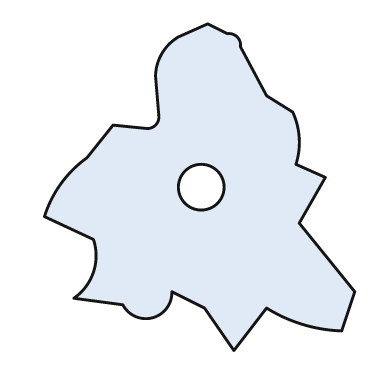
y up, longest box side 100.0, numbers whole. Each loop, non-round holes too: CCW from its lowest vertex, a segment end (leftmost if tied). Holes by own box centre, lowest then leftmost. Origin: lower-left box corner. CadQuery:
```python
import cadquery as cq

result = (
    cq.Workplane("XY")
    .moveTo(58.0, 0.0)
    .lineTo(68.0, 13.0)
    .threePointArc((79.0, 8.0), (91.0, 6.0))
    .lineTo(95.0, 18.0)
    .lineTo(78.0, 39.0)
    .lineTo(86.0, 53.0)
    .lineTo(77.0, 57.0)
    .threePointArc((78.0, 65.0), (76.0, 73.0))
    .lineTo(68.0, 78.0)
    .lineTo(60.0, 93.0)
    .threePointArc((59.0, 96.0), (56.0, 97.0))
    .lineTo(50.0, 100.0)
    .lineTo(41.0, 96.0)
    .threePointArc((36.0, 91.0), (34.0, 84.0))
    .lineTo(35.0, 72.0)
    .threePointArc((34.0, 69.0), (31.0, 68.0))
    .lineTo(21.0, 69.0)
    .lineTo(13.0, 59.0)
    .threePointArc((5.0, 51.0), (0.0, 41.0))
    .lineTo(15.0, 34.0)
    .threePointArc((15.0, 24.0), (9.0, 16.0))
    .lineTo(24.0, 14.0)
    .threePointArc((33.0, 10.0), (39.0, 18.0))
    .lineTo(49.0, 13.0)
    .close()
    .moveTo(48.0, 50.0)
    .circle(7.0)
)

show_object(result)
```